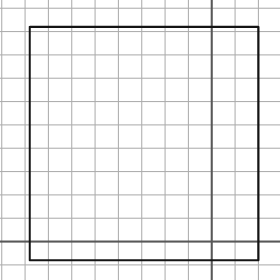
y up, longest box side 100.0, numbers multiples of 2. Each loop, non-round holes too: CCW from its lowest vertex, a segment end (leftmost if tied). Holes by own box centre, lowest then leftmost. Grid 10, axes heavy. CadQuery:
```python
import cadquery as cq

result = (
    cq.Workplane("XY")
    .moveTo(-78.0, -8.0)
    .lineTo(20.0, -8.0)
    .lineTo(20.0, 92.0)
    .lineTo(-78.0, 92.0)
    .close()
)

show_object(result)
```